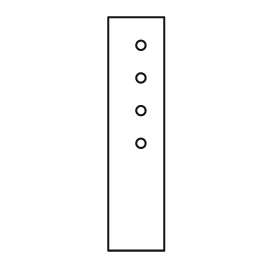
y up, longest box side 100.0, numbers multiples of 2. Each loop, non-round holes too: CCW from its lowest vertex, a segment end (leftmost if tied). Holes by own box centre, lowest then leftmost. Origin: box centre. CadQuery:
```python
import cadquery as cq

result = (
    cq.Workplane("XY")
    .moveTo(-12.0, -50.0)
    .lineTo(12.0, -50.0)
    .lineTo(12.0, 50.0)
    .lineTo(-12.0, 50.0)
    .close()
    .moveTo(2.0, -4.0)
    .circle(2.0)
    .moveTo(2.0, 10.0)
    .circle(2.0)
    .moveTo(2.0, 24.0)
    .circle(2.0)
    .moveTo(2.0, 38.0)
    .circle(2.0)
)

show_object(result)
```